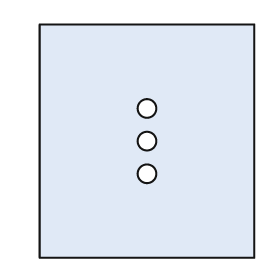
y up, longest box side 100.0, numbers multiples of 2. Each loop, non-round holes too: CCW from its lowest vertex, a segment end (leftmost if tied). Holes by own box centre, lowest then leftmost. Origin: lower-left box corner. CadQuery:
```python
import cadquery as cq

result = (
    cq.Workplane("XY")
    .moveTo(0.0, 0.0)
    .lineTo(92.0, 0.0)
    .lineTo(92.0, 100.0)
    .lineTo(0.0, 100.0)
    .close()
    .moveTo(46.0, 36.0)
    .circle(4.0)
    .moveTo(46.0, 50.0)
    .circle(4.0)
    .moveTo(46.0, 64.0)
    .circle(4.0)
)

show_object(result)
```